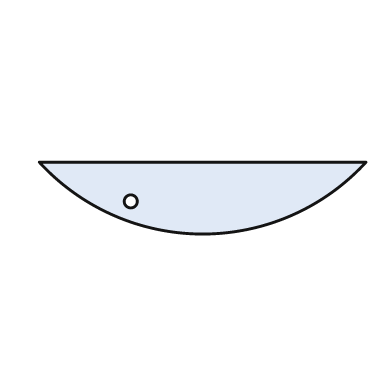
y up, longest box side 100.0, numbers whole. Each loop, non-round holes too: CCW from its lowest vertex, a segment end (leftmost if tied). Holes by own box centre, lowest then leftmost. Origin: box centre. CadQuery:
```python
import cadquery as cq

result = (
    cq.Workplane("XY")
    .moveTo(-50.0, 11.0)
    .threePointArc((0.0, -11.0), (50.0, 11.0))
    .close()
    .moveTo(-22.0, -1.0)
    .circle(2.0)
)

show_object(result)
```